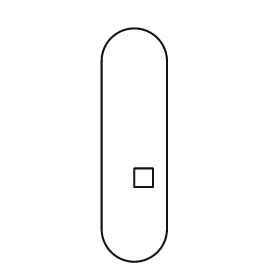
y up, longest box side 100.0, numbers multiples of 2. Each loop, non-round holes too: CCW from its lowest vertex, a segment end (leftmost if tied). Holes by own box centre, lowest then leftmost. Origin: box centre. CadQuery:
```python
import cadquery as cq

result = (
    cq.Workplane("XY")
    .moveTo(-14.0, -36.0)
    .threePointArc((0.0, -50.0), (14.0, -36.0))
    .lineTo(14.0, 36.0)
    .threePointArc((0.0, 50.0), (-14.0, 36.0))
    .close()
    .moveTo(0.0, -18.0)
    .lineTo(8.0, -18.0)
    .lineTo(8.0, -10.0)
    .lineTo(0.0, -10.0)
    .close()
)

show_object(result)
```